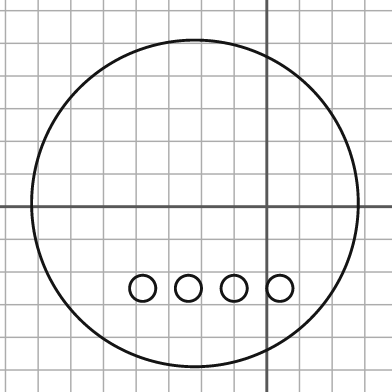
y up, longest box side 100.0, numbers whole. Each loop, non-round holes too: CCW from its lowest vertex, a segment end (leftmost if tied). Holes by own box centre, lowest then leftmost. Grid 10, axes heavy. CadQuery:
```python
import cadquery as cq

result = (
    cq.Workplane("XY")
    .moveTo(-22.0, 1.0)
    .circle(50.0)
    .moveTo(-38.0, -25.0)
    .circle(4.0)
    .moveTo(-24.0, -25.0)
    .circle(4.0)
    .moveTo(-10.0, -25.0)
    .circle(4.0)
    .moveTo(4.0, -25.0)
    .circle(4.0)
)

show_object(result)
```